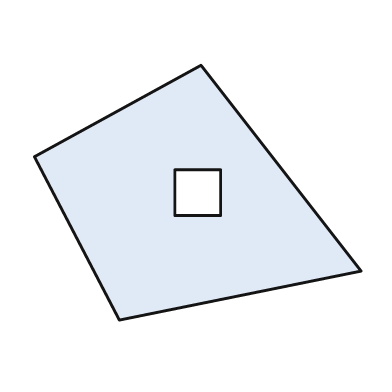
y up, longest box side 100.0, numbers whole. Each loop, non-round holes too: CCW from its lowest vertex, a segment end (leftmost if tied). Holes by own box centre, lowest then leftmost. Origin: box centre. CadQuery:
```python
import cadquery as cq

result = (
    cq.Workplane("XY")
    .moveTo(-24.0, -39.0)
    .lineTo(50.0, -24.0)
    .lineTo(1.0, 39.0)
    .lineTo(-50.0, 11.0)
    .close()
    .moveTo(-7.0, -7.0)
    .lineTo(7.0, -7.0)
    .lineTo(7.0, 7.0)
    .lineTo(-7.0, 7.0)
    .close()
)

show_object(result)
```